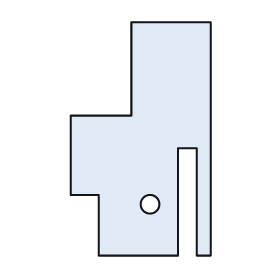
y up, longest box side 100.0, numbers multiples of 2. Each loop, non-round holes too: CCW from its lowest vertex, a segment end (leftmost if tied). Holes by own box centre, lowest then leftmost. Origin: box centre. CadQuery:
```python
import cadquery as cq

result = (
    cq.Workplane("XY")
    .moveTo(-18.0, -50.0)
    .lineTo(16.0, -50.0)
    .lineTo(16.0, -4.0)
    .lineTo(24.0, -4.0)
    .lineTo(24.0, -50.0)
    .lineTo(30.0, -50.0)
    .lineTo(30.0, 50.0)
    .lineTo(-4.0, 50.0)
    .lineTo(-4.0, 10.0)
    .lineTo(-30.0, 10.0)
    .lineTo(-30.0, -24.0)
    .lineTo(-18.0, -24.0)
    .close()
    .moveTo(4.0, -28.0)
    .circle(4.0)
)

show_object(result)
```